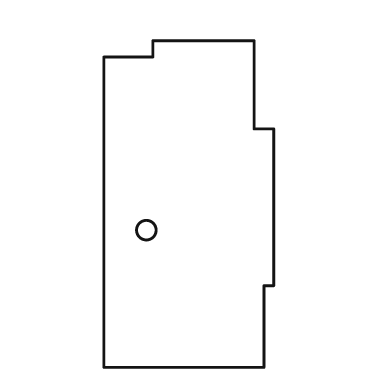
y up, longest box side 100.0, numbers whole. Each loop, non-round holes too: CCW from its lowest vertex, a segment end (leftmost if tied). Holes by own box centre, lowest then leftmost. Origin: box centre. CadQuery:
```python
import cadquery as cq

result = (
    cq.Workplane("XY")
    .moveTo(-26.0, -50.0)
    .lineTo(23.0, -50.0)
    .lineTo(23.0, -25.0)
    .lineTo(26.0, -25.0)
    .lineTo(26.0, 23.0)
    .lineTo(20.0, 23.0)
    .lineTo(20.0, 50.0)
    .lineTo(-11.0, 50.0)
    .lineTo(-11.0, 45.0)
    .lineTo(-26.0, 45.0)
    .close()
    .moveTo(-13.0, -8.0)
    .circle(3.0)
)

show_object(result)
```